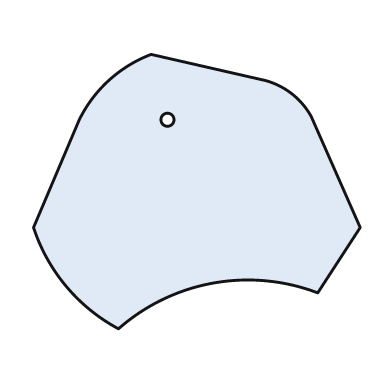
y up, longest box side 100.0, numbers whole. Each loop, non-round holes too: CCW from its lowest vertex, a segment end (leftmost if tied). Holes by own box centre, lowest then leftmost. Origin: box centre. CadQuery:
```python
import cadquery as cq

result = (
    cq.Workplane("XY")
    .moveTo(-24.0, -42.0)
    .threePointArc((5.0, -28.0), (37.0, -31.0))
    .lineTo(50.0, -11.0)
    .lineTo(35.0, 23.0)
    .threePointArc((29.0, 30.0), (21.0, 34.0))
    .lineTo(-14.0, 42.0)
    .threePointArc((-27.0, 34.0), (-36.0, 22.0))
    .lineTo(-50.0, -11.0)
    .threePointArc((-40.0, -29.0), (-24.0, -42.0))
    .close()
    .moveTo(-9.0, 22.0)
    .circle(2.0)
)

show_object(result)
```